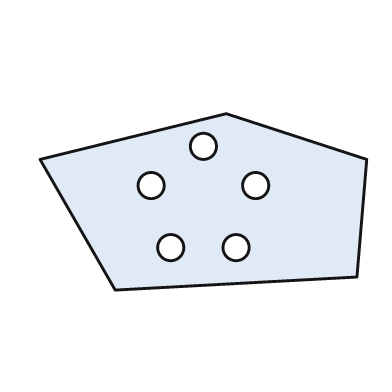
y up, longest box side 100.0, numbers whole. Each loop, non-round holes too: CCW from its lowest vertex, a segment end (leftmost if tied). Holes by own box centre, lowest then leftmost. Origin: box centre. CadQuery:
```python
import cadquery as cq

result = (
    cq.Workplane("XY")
    .moveTo(-27.0, -27.0)
    .lineTo(47.0, -23.0)
    .lineTo(50.0, 13.0)
    .lineTo(7.0, 27.0)
    .lineTo(-50.0, 13.0)
    .close()
    .moveTo(-10.0, -14.0)
    .circle(4.0)
    .moveTo(10.0, -14.0)
    .circle(4.0)
    .moveTo(-16.0, 5.0)
    .circle(4.0)
    .moveTo(16.0, 5.0)
    .circle(4.0)
    .moveTo(0.0, 17.0)
    .circle(4.0)
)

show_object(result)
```